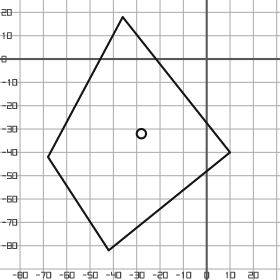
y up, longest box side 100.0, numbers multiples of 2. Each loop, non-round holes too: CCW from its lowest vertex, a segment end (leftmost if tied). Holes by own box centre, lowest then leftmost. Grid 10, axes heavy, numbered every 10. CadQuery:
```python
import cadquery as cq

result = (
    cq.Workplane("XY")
    .moveTo(-42.0, -82.0)
    .lineTo(10.0, -40.0)
    .lineTo(-36.0, 18.0)
    .lineTo(-68.0, -42.0)
    .close()
    .moveTo(-28.0, -32.0)
    .circle(2.0)
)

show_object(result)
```